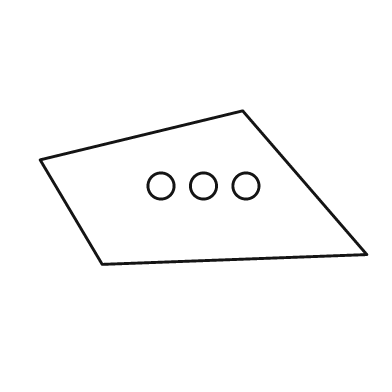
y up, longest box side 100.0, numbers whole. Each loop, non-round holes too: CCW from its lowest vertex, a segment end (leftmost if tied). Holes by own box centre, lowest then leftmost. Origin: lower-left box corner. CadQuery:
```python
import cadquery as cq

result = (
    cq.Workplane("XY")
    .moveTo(19.0, 0.0)
    .lineTo(100.0, 3.0)
    .lineTo(62.0, 47.0)
    .lineTo(0.0, 32.0)
    .close()
    .moveTo(37.0, 24.0)
    .circle(4.0)
    .moveTo(50.0, 24.0)
    .circle(4.0)
    .moveTo(63.0, 24.0)
    .circle(4.0)
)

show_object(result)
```